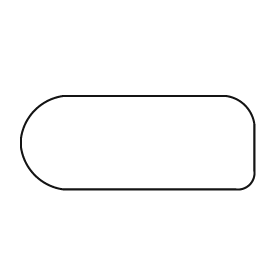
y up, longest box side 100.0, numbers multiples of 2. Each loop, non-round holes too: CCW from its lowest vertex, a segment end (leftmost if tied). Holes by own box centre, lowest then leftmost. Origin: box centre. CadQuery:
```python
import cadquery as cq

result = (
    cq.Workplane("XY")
    .moveTo(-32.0, -20.0)
    .lineTo(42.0, -20.0)
    .threePointArc((48.0, -18.0), (50.0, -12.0))
    .lineTo(50.0, 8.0)
    .threePointArc((46.0, 16.0), (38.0, 20.0))
    .lineTo(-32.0, 20.0)
    .threePointArc((-44.0, 14.0), (-50.0, 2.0))
    .lineTo(-50.0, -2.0)
    .threePointArc((-44.0, -14.0), (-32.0, -20.0))
    .close()
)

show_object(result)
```